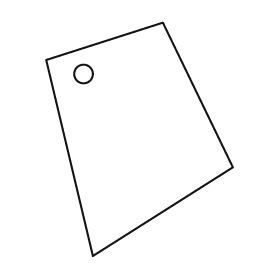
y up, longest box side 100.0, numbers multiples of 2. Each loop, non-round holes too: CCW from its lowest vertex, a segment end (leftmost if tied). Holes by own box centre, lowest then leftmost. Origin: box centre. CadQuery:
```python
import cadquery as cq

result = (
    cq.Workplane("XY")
    .moveTo(-20.0, -50.0)
    .lineTo(40.0, -12.0)
    .lineTo(10.0, 50.0)
    .lineTo(-40.0, 34.0)
    .close()
    .moveTo(-24.0, 28.0)
    .circle(4.0)
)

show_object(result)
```